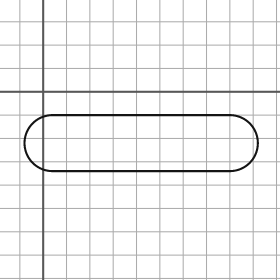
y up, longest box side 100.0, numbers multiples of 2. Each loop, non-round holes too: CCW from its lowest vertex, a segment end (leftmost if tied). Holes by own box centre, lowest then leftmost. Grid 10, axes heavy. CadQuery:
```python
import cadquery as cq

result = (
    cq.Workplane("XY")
    .moveTo(4.0, -34.0)
    .lineTo(80.0, -34.0)
    .threePointArc((92.0, -22.0), (80.0, -10.0))
    .lineTo(4.0, -10.0)
    .threePointArc((-8.0, -22.0), (4.0, -34.0))
    .close()
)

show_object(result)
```